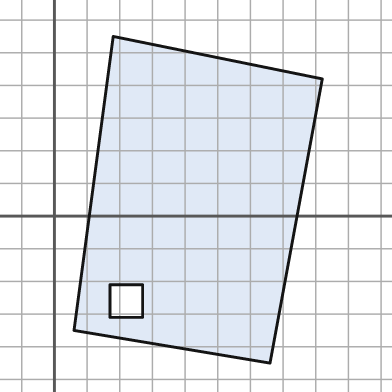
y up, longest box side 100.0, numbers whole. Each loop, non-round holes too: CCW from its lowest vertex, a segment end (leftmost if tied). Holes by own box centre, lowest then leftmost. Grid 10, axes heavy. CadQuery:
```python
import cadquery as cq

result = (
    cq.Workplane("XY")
    .moveTo(66.0, -45.0)
    .lineTo(82.0, 42.0)
    .lineTo(18.0, 55.0)
    .lineTo(6.0, -35.0)
    .close()
    .moveTo(17.0, -31.0)
    .lineTo(27.0, -31.0)
    .lineTo(27.0, -21.0)
    .lineTo(17.0, -21.0)
    .close()
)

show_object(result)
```